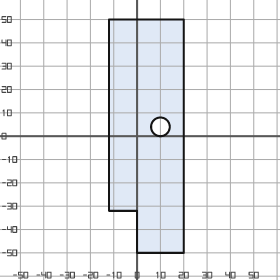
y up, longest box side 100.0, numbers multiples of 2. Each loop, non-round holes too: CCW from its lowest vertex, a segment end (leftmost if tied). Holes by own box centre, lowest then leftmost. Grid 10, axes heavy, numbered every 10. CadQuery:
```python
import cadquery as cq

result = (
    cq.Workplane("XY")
    .moveTo(0.0, -50.0)
    .lineTo(20.0, -50.0)
    .lineTo(20.0, 50.0)
    .lineTo(-12.0, 50.0)
    .lineTo(-12.0, -32.0)
    .lineTo(0.0, -32.0)
    .close()
    .moveTo(10.0, 4.0)
    .circle(4.0)
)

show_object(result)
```